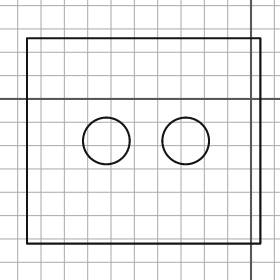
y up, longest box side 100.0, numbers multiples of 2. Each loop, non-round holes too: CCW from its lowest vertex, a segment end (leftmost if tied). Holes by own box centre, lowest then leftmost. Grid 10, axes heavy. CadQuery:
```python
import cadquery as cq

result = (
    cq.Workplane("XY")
    .moveTo(-96.0, -62.0)
    .lineTo(4.0, -62.0)
    .lineTo(4.0, 26.0)
    .lineTo(-96.0, 26.0)
    .close()
    .moveTo(-62.0, -18.0)
    .circle(10.0)
    .moveTo(-28.0, -18.0)
    .circle(10.0)
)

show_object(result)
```